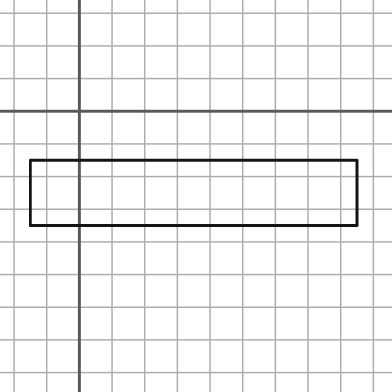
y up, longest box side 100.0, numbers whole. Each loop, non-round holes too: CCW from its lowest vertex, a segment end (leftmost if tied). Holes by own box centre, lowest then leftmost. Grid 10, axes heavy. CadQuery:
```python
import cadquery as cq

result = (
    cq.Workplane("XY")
    .moveTo(-15.0, -35.0)
    .lineTo(85.0, -35.0)
    .lineTo(85.0, -15.0)
    .lineTo(-15.0, -15.0)
    .close()
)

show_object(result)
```